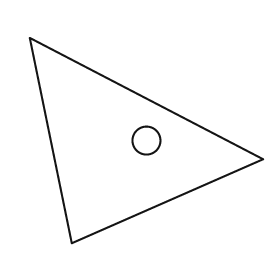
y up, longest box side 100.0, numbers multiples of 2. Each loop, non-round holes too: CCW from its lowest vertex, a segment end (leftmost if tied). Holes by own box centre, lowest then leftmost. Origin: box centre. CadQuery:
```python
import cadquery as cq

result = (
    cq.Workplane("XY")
    .moveTo(-32.0, -44.0)
    .lineTo(50.0, -8.0)
    .lineTo(-50.0, 44.0)
    .close()
    .moveTo(0.0, 0.0)
    .circle(6.0)
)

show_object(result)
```